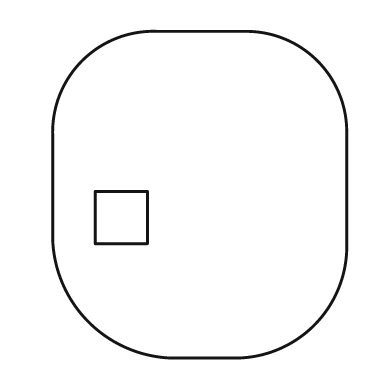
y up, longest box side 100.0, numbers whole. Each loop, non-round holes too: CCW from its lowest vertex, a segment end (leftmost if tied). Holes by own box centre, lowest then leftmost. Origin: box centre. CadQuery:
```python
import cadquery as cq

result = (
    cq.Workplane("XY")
    .moveTo(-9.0, -50.0)
    .lineTo(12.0, -50.0)
    .threePointArc((35.0, -40.0), (45.0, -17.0))
    .lineTo(45.0, 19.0)
    .threePointArc((36.0, 41.0), (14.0, 50.0))
    .lineTo(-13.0, 50.0)
    .threePointArc((-36.0, 41.0), (-45.0, 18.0))
    .lineTo(-45.0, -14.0)
    .threePointArc((-34.0, -39.0), (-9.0, -50.0))
    .close()
    .moveTo(-32.0, -15.0)
    .lineTo(-16.0, -15.0)
    .lineTo(-16.0, 1.0)
    .lineTo(-32.0, 1.0)
    .close()
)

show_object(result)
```